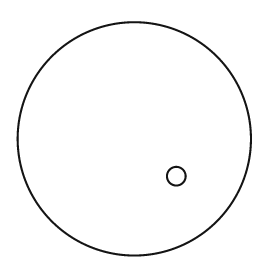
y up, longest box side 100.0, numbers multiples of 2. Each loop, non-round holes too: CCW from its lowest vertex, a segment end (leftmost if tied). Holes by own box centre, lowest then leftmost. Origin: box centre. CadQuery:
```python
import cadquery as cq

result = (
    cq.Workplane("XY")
    .moveTo(0.0, 0.0)
    .circle(50.0)
    .moveTo(18.0, -16.0)
    .circle(4.0)
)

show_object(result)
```